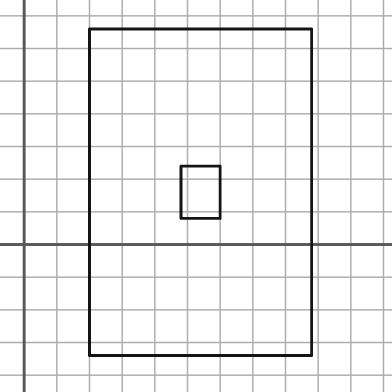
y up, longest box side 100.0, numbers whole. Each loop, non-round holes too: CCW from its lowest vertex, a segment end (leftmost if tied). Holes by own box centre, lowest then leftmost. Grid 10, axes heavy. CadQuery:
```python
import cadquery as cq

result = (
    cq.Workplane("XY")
    .moveTo(20.0, -34.0)
    .lineTo(88.0, -34.0)
    .lineTo(88.0, 66.0)
    .lineTo(20.0, 66.0)
    .close()
    .moveTo(48.0, 8.0)
    .lineTo(60.0, 8.0)
    .lineTo(60.0, 24.0)
    .lineTo(48.0, 24.0)
    .close()
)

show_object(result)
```